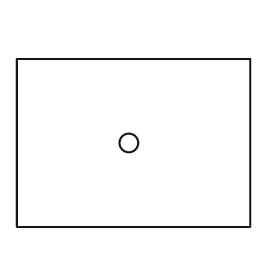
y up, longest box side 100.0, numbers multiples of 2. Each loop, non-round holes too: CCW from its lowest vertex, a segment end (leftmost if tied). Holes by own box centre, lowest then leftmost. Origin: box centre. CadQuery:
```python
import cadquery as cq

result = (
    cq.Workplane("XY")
    .moveTo(-50.0, -36.0)
    .lineTo(50.0, -36.0)
    .lineTo(50.0, 36.0)
    .lineTo(-50.0, 36.0)
    .close()
    .moveTo(-2.0, 0.0)
    .circle(4.0)
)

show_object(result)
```